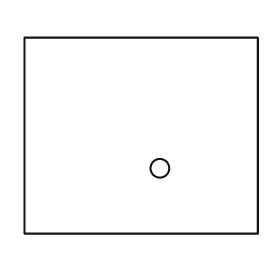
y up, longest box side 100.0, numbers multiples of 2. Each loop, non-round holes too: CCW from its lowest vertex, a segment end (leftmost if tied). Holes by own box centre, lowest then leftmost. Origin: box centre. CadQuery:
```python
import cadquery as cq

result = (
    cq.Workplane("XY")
    .moveTo(-50.0, -42.0)
    .lineTo(50.0, -42.0)
    .lineTo(50.0, 42.0)
    .lineTo(-50.0, 42.0)
    .close()
    .moveTo(8.0, -14.0)
    .circle(4.0)
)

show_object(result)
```